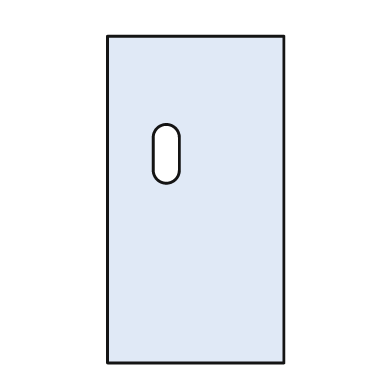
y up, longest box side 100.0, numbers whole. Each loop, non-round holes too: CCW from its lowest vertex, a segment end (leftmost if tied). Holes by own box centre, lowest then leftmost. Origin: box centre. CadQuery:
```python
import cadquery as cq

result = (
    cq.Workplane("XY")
    .moveTo(-27.0, -50.0)
    .lineTo(27.0, -50.0)
    .lineTo(27.0, 50.0)
    .lineTo(-27.0, 50.0)
    .close()
    .moveTo(-13.0, 9.0)
    .threePointArc((-9.0, 5.0), (-5.0, 9.0))
    .lineTo(-5.0, 19.0)
    .threePointArc((-9.0, 23.0), (-13.0, 19.0))
    .close()
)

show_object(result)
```